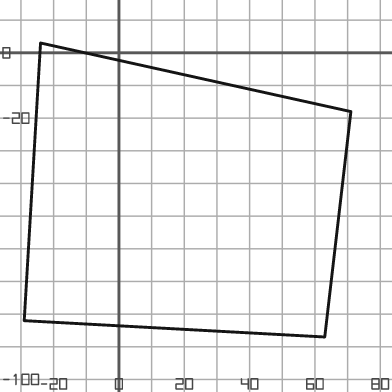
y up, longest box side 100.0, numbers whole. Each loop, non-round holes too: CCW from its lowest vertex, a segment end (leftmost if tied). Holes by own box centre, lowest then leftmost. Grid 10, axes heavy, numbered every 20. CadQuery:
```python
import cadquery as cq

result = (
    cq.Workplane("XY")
    .moveTo(63.0, -87.0)
    .lineTo(71.0, -18.0)
    .lineTo(-24.0, 3.0)
    .lineTo(-29.0, -82.0)
    .close()
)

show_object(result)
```